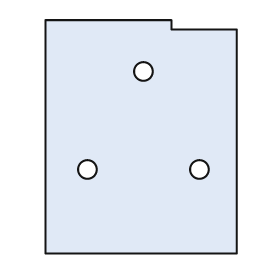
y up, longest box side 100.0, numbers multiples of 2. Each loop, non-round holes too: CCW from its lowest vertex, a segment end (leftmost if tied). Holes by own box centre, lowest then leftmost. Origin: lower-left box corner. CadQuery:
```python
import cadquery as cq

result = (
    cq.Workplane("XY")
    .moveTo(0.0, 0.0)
    .lineTo(82.0, 0.0)
    .lineTo(82.0, 96.0)
    .lineTo(54.0, 96.0)
    .lineTo(54.0, 100.0)
    .lineTo(0.0, 100.0)
    .close()
    .moveTo(18.0, 36.0)
    .circle(4.0)
    .moveTo(66.0, 36.0)
    .circle(4.0)
    .moveTo(42.0, 78.0)
    .circle(4.0)
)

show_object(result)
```